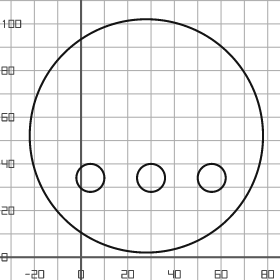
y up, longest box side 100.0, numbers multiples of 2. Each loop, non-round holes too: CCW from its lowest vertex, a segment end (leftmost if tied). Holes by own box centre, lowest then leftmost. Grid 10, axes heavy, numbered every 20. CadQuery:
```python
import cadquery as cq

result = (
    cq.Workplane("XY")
    .moveTo(28.0, 52.0)
    .circle(50.0)
    .moveTo(4.0, 34.0)
    .circle(6.0)
    .moveTo(30.0, 34.0)
    .circle(6.0)
    .moveTo(56.0, 34.0)
    .circle(6.0)
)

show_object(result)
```